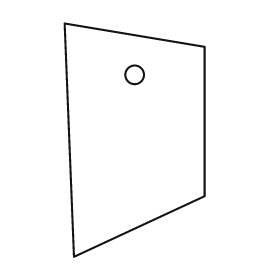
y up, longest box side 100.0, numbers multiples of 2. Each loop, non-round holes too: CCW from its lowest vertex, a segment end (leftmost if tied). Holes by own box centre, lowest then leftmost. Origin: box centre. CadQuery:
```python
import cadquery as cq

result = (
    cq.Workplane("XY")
    .moveTo(-26.0, -50.0)
    .lineTo(30.0, -24.0)
    .lineTo(30.0, 40.0)
    .lineTo(-30.0, 50.0)
    .close()
    .moveTo(0.0, 28.0)
    .circle(4.0)
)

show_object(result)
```